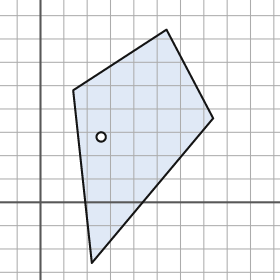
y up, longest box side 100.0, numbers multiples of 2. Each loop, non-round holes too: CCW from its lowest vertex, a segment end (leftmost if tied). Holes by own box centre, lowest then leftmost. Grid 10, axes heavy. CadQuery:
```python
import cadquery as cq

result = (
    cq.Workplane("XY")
    .moveTo(22.0, -26.0)
    .lineTo(74.0, 36.0)
    .lineTo(54.0, 74.0)
    .lineTo(14.0, 48.0)
    .close()
    .moveTo(26.0, 28.0)
    .circle(2.0)
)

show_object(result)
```